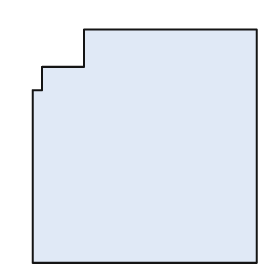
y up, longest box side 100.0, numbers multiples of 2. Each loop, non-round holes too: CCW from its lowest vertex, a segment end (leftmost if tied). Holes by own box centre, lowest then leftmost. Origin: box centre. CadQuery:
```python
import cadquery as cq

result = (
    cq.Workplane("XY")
    .moveTo(-48.0, -50.0)
    .lineTo(48.0, -50.0)
    .lineTo(48.0, 50.0)
    .lineTo(-26.0, 50.0)
    .lineTo(-26.0, 34.0)
    .lineTo(-44.0, 34.0)
    .lineTo(-44.0, 24.0)
    .lineTo(-48.0, 24.0)
    .close()
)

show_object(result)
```